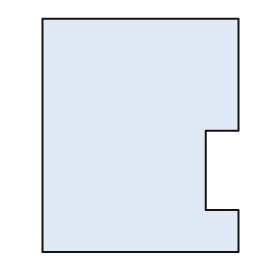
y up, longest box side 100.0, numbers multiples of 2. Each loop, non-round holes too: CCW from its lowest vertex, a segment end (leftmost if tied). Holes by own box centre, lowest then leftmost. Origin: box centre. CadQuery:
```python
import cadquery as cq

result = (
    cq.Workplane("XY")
    .moveTo(-42.0, -50.0)
    .lineTo(42.0, -50.0)
    .lineTo(42.0, -32.0)
    .lineTo(28.0, -32.0)
    .lineTo(28.0, 2.0)
    .lineTo(42.0, 2.0)
    .lineTo(42.0, 50.0)
    .lineTo(-42.0, 50.0)
    .close()
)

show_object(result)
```